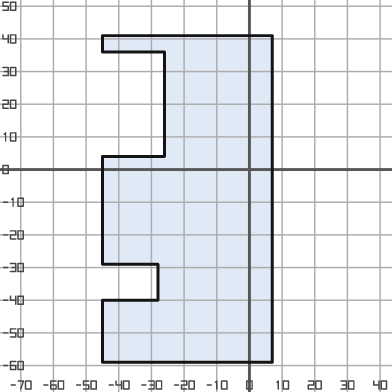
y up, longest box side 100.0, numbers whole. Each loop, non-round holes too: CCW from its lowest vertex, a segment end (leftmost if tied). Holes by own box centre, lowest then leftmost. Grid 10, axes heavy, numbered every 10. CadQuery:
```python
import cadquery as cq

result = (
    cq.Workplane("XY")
    .moveTo(-45.0, -59.0)
    .lineTo(7.0, -59.0)
    .lineTo(7.0, 41.0)
    .lineTo(-45.0, 41.0)
    .lineTo(-45.0, 36.0)
    .lineTo(-26.0, 36.0)
    .lineTo(-26.0, 4.0)
    .lineTo(-45.0, 4.0)
    .lineTo(-45.0, -29.0)
    .lineTo(-28.0, -29.0)
    .lineTo(-28.0, -40.0)
    .lineTo(-45.0, -40.0)
    .close()
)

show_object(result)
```